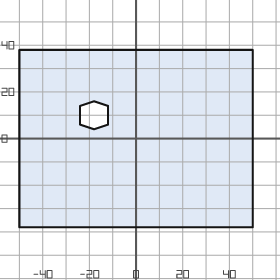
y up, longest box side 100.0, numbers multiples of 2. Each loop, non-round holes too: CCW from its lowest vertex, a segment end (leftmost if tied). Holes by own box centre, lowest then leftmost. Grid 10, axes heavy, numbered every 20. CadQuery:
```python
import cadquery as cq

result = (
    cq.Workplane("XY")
    .moveTo(-50.0, -38.0)
    .lineTo(50.0, -38.0)
    .lineTo(50.0, 38.0)
    .lineTo(-50.0, 38.0)
    .close()
    .moveTo(-18.0, 4.0)
    .lineTo(-12.0, 6.0)
    .lineTo(-12.0, 14.0)
    .lineTo(-18.0, 16.0)
    .lineTo(-24.0, 14.0)
    .lineTo(-24.0, 6.0)
    .close()
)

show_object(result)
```